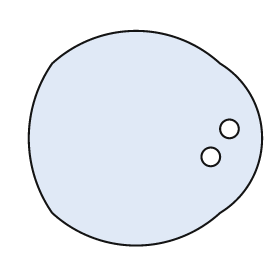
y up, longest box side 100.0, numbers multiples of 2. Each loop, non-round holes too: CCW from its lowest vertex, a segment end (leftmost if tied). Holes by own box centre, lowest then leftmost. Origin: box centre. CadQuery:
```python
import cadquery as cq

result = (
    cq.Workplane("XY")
    .moveTo(-40.0, -32.0)
    .threePointArc((-4.0, -46.0), (32.0, -32.0))
    .threePointArc((50.0, 0.0), (32.0, 32.0))
    .threePointArc((-4.0, 46.0), (-40.0, 32.0))
    .threePointArc((-50.0, 0.0), (-40.0, -32.0))
    .close()
    .moveTo(28.0, -8.0)
    .circle(4.0)
    .moveTo(36.0, 4.0)
    .circle(4.0)
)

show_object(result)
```